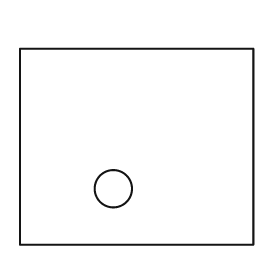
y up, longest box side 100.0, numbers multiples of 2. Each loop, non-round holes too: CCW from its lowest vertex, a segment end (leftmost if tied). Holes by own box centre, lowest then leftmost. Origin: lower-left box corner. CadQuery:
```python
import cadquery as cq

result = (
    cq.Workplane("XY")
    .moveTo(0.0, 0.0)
    .lineTo(100.0, 0.0)
    .lineTo(100.0, 84.0)
    .lineTo(0.0, 84.0)
    .close()
    .moveTo(40.0, 24.0)
    .circle(8.0)
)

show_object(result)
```